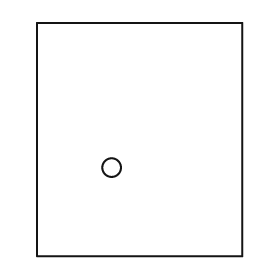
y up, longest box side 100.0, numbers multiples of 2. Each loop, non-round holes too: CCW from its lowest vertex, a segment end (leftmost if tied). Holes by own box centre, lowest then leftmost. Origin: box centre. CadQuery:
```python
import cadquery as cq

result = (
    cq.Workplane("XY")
    .moveTo(-44.0, -50.0)
    .lineTo(44.0, -50.0)
    .lineTo(44.0, 50.0)
    .lineTo(-44.0, 50.0)
    .close()
    .moveTo(-12.0, -12.0)
    .circle(4.0)
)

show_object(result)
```